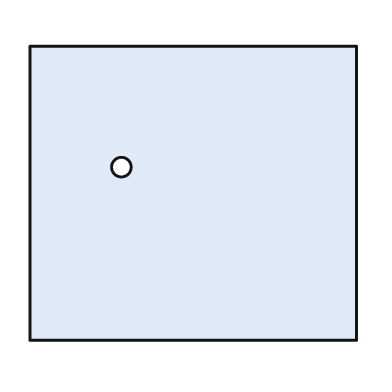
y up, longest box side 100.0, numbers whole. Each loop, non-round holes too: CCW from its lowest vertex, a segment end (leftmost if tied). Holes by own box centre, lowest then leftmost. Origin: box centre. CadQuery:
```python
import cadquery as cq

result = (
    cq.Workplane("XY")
    .moveTo(-50.0, -45.0)
    .lineTo(50.0, -45.0)
    .lineTo(50.0, 45.0)
    .lineTo(-50.0, 45.0)
    .close()
    .moveTo(-22.0, 8.0)
    .circle(3.0)
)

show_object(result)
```